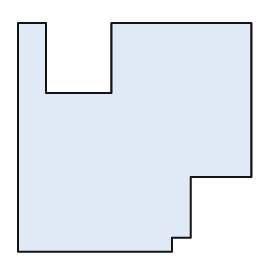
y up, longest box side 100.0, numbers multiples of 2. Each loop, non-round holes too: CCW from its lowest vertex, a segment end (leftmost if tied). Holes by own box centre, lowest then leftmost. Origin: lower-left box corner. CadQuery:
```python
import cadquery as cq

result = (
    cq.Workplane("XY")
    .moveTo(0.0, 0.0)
    .lineTo(66.0, 0.0)
    .lineTo(66.0, 6.0)
    .lineTo(74.0, 6.0)
    .lineTo(74.0, 32.0)
    .lineTo(100.0, 32.0)
    .lineTo(100.0, 98.0)
    .lineTo(40.0, 98.0)
    .lineTo(40.0, 68.0)
    .lineTo(12.0, 68.0)
    .lineTo(12.0, 98.0)
    .lineTo(0.0, 98.0)
    .close()
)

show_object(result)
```